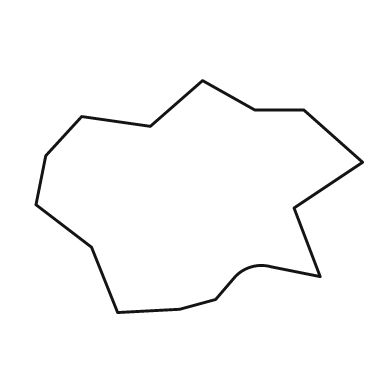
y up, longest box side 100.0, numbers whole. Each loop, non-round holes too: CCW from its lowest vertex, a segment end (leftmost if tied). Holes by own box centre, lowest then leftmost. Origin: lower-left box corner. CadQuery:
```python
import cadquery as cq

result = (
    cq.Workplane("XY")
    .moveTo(25.0, 0.0)
    .lineTo(44.0, 1.0)
    .lineTo(55.0, 4.0)
    .lineTo(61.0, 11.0)
    .threePointArc((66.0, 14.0), (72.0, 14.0))
    .lineTo(87.0, 11.0)
    .lineTo(79.0, 32.0)
    .lineTo(100.0, 46.0)
    .lineTo(82.0, 62.0)
    .lineTo(67.0, 62.0)
    .lineTo(51.0, 71.0)
    .lineTo(35.0, 57.0)
    .lineTo(14.0, 60.0)
    .lineTo(3.0, 48.0)
    .lineTo(0.0, 33.0)
    .lineTo(17.0, 20.0)
    .close()
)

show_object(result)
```